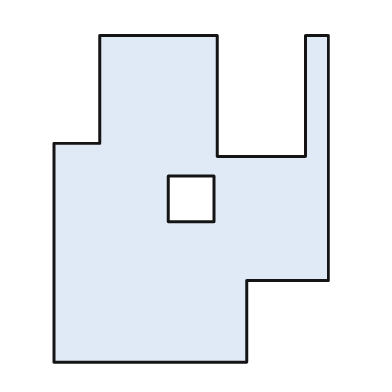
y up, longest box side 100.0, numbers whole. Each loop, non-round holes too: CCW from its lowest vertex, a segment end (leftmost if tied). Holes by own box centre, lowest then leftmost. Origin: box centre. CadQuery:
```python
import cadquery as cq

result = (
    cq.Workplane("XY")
    .moveTo(-42.0, -50.0)
    .lineTo(17.0, -50.0)
    .lineTo(17.0, -25.0)
    .lineTo(42.0, -25.0)
    .lineTo(42.0, 50.0)
    .lineTo(35.0, 50.0)
    .lineTo(35.0, 13.0)
    .lineTo(8.0, 13.0)
    .lineTo(8.0, 50.0)
    .lineTo(-28.0, 50.0)
    .lineTo(-28.0, 17.0)
    .lineTo(-42.0, 17.0)
    .close()
    .moveTo(-7.0, -7.0)
    .lineTo(7.0, -7.0)
    .lineTo(7.0, 7.0)
    .lineTo(-7.0, 7.0)
    .close()
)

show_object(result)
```